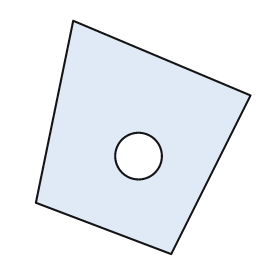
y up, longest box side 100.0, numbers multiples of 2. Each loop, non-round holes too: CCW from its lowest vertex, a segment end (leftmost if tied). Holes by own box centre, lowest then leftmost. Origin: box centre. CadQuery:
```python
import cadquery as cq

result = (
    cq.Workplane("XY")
    .moveTo(12.0, -50.0)
    .lineTo(46.0, 18.0)
    .lineTo(-30.0, 50.0)
    .lineTo(-46.0, -28.0)
    .close()
    .moveTo(-2.0, -8.0)
    .circle(10.0)
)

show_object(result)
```